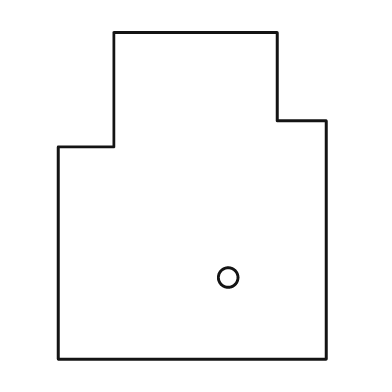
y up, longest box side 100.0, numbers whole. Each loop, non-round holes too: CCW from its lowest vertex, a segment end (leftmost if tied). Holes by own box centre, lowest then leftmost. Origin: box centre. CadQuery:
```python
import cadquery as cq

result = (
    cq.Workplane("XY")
    .moveTo(-41.0, -50.0)
    .lineTo(41.0, -50.0)
    .lineTo(41.0, 23.0)
    .lineTo(26.0, 23.0)
    .lineTo(26.0, 50.0)
    .lineTo(-24.0, 50.0)
    .lineTo(-24.0, 15.0)
    .lineTo(-41.0, 15.0)
    .close()
    .moveTo(11.0, -25.0)
    .circle(3.0)
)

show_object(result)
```